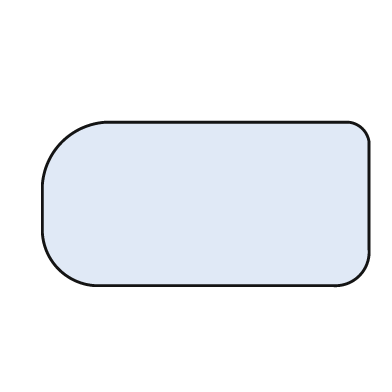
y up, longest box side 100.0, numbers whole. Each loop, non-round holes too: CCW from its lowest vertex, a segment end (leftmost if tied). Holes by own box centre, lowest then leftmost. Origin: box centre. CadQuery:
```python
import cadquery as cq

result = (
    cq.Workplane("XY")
    .moveTo(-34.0, -25.0)
    .lineTo(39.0, -25.0)
    .threePointArc((47.0, -22.0), (50.0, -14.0))
    .lineTo(50.0, 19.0)
    .threePointArc((48.0, 23.0), (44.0, 25.0))
    .lineTo(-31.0, 25.0)
    .threePointArc((-44.0, 19.0), (-50.0, 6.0))
    .lineTo(-50.0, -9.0)
    .threePointArc((-45.0, -20.0), (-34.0, -25.0))
    .close()
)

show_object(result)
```